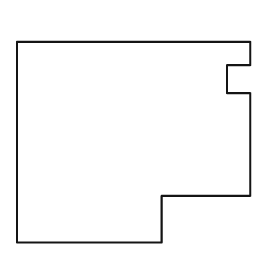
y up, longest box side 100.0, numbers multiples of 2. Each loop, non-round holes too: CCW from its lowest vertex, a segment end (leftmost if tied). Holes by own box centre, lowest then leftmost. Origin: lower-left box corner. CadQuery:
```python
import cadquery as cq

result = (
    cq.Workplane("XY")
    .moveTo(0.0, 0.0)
    .lineTo(62.0, 0.0)
    .lineTo(62.0, 20.0)
    .lineTo(100.0, 20.0)
    .lineTo(100.0, 64.0)
    .lineTo(90.0, 64.0)
    .lineTo(90.0, 76.0)
    .lineTo(100.0, 76.0)
    .lineTo(100.0, 86.0)
    .lineTo(0.0, 86.0)
    .close()
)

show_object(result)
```